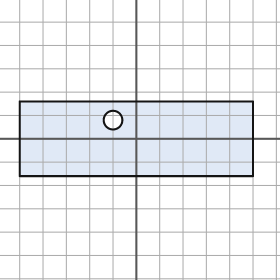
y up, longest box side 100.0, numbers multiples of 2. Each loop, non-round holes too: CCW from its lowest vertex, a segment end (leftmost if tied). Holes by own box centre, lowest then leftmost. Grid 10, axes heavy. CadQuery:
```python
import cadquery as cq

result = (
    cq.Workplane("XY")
    .moveTo(-50.0, -16.0)
    .lineTo(50.0, -16.0)
    .lineTo(50.0, 16.0)
    .lineTo(-50.0, 16.0)
    .close()
    .moveTo(-10.0, 8.0)
    .circle(4.0)
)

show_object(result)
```